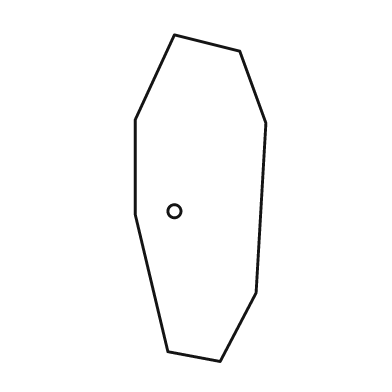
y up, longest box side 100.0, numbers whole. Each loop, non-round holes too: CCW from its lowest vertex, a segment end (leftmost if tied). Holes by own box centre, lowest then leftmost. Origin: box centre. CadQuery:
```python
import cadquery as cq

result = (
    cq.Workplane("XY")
    .moveTo(6.0, -50.0)
    .lineTo(17.0, -29.0)
    .lineTo(20.0, 23.0)
    .lineTo(12.0, 45.0)
    .lineTo(-8.0, 50.0)
    .lineTo(-20.0, 24.0)
    .lineTo(-20.0, -5.0)
    .lineTo(-10.0, -47.0)
    .close()
    .moveTo(-8.0, -4.0)
    .circle(2.0)
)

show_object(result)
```